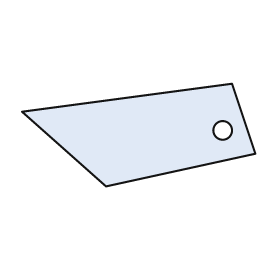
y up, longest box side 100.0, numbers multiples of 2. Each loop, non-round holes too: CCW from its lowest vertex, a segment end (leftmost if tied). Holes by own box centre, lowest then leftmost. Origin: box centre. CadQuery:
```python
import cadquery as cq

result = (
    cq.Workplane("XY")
    .moveTo(-14.0, -22.0)
    .lineTo(50.0, -8.0)
    .lineTo(40.0, 22.0)
    .lineTo(-50.0, 10.0)
    .close()
    .moveTo(36.0, 2.0)
    .circle(4.0)
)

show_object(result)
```